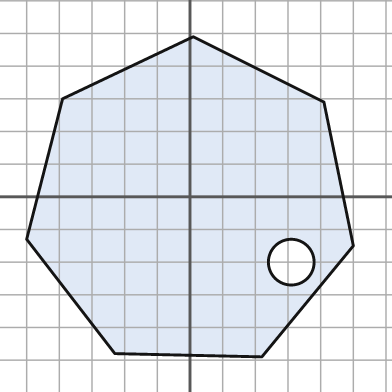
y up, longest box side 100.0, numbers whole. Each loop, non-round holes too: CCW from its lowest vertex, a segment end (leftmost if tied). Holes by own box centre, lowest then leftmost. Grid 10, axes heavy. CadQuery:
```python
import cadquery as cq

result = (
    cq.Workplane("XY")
    .moveTo(22.0, -49.0)
    .lineTo(50.0, -15.0)
    .lineTo(41.0, 29.0)
    .lineTo(1.0, 49.0)
    .lineTo(-39.0, 30.0)
    .lineTo(-50.0, -13.0)
    .lineTo(-23.0, -48.0)
    .close()
    .moveTo(31.0, -20.0)
    .circle(7.0)
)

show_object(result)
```